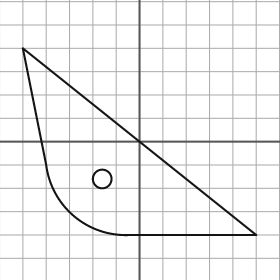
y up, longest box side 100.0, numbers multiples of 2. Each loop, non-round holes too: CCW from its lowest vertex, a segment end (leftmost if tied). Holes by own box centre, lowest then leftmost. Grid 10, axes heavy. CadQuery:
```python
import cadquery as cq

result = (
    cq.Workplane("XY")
    .moveTo(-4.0, -40.0)
    .lineTo(50.0, -40.0)
    .lineTo(-50.0, 40.0)
    .lineTo(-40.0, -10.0)
    .threePointArc((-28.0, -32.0), (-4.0, -40.0))
    .close()
    .moveTo(-16.0, -16.0)
    .circle(4.0)
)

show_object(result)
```